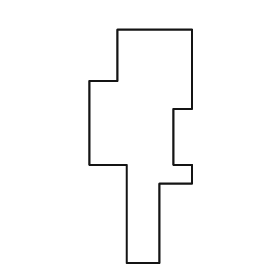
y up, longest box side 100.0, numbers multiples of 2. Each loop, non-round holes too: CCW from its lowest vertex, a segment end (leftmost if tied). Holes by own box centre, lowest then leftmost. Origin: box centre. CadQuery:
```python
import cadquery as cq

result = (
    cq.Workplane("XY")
    .moveTo(-6.0, -50.0)
    .lineTo(8.0, -50.0)
    .lineTo(8.0, -16.0)
    .lineTo(22.0, -16.0)
    .lineTo(22.0, -8.0)
    .lineTo(14.0, -8.0)
    .lineTo(14.0, 16.0)
    .lineTo(22.0, 16.0)
    .lineTo(22.0, 50.0)
    .lineTo(-10.0, 50.0)
    .lineTo(-10.0, 28.0)
    .lineTo(-22.0, 28.0)
    .lineTo(-22.0, -8.0)
    .lineTo(-6.0, -8.0)
    .close()
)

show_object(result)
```